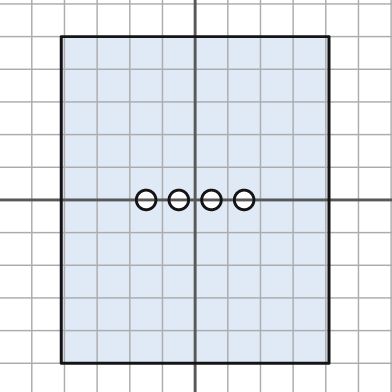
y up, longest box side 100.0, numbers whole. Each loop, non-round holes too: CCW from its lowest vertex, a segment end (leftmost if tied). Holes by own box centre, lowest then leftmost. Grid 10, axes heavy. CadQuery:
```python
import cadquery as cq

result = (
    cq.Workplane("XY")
    .moveTo(-41.0, -50.0)
    .lineTo(41.0, -50.0)
    .lineTo(41.0, 50.0)
    .lineTo(-41.0, 50.0)
    .close()
    .moveTo(-15.0, 0.0)
    .circle(3.0)
    .moveTo(-5.0, 0.0)
    .circle(3.0)
    .moveTo(5.0, 0.0)
    .circle(3.0)
    .moveTo(15.0, 0.0)
    .circle(3.0)
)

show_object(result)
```